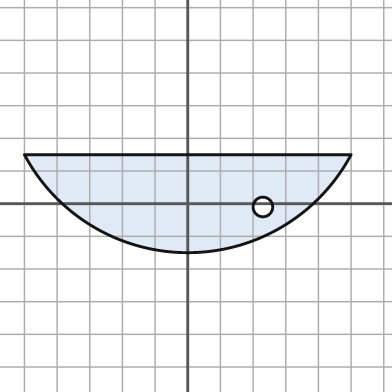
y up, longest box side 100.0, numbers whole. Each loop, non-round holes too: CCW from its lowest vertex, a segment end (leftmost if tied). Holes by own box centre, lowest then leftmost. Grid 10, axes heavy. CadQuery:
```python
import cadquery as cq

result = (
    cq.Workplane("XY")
    .moveTo(-50.0, 15.0)
    .threePointArc((0.0, -15.0), (50.0, 15.0))
    .close()
    .moveTo(23.0, -1.0)
    .circle(3.0)
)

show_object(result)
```